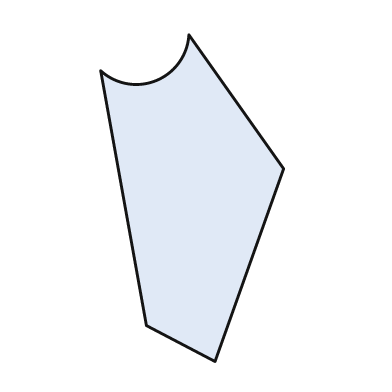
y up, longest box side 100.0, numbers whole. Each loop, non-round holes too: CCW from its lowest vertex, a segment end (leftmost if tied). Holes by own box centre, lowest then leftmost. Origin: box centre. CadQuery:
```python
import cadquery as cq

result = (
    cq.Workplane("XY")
    .moveTo(7.0, -50.0)
    .lineTo(28.0, 9.0)
    .lineTo(-1.0, 50.0)
    .threePointArc((-11.0, 36.0), (-28.0, 39.0))
    .lineTo(-14.0, -39.0)
    .close()
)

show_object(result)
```